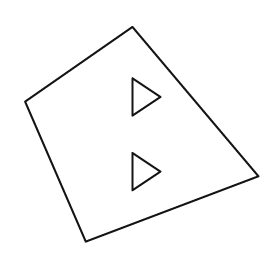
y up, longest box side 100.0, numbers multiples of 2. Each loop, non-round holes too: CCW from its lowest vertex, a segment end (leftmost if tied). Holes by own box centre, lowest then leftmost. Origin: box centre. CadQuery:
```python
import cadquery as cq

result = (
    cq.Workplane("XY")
    .moveTo(-24.0, -46.0)
    .lineTo(50.0, -18.0)
    .lineTo(-4.0, 46.0)
    .lineTo(-50.0, 14.0)
    .close()
    .moveTo(-4.0, -24.0)
    .lineTo(8.0, -16.0)
    .lineTo(-4.0, -8.0)
    .close()
    .moveTo(-4.0, 8.0)
    .lineTo(8.0, 16.0)
    .lineTo(-4.0, 24.0)
    .close()
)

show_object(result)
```